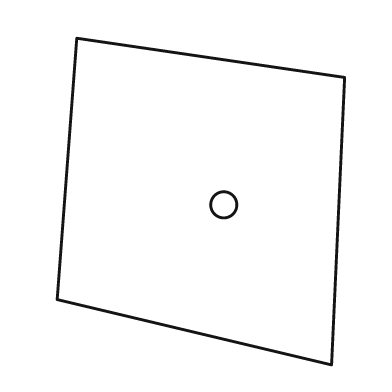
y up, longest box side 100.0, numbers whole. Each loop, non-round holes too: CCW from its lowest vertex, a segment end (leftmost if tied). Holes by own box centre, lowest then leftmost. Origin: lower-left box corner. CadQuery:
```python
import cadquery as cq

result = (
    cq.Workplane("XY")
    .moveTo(84.0, 0.0)
    .lineTo(88.0, 88.0)
    .lineTo(6.0, 100.0)
    .lineTo(0.0, 20.0)
    .close()
    .moveTo(51.0, 49.0)
    .circle(4.0)
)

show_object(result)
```